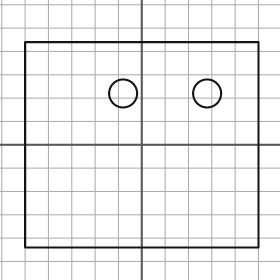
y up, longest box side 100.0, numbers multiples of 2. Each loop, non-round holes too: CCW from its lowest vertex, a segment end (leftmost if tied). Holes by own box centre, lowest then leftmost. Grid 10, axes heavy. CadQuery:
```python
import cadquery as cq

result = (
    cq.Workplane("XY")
    .moveTo(-50.0, -44.0)
    .lineTo(50.0, -44.0)
    .lineTo(50.0, 44.0)
    .lineTo(-50.0, 44.0)
    .close()
    .moveTo(-8.0, 22.0)
    .circle(6.0)
    .moveTo(28.0, 22.0)
    .circle(6.0)
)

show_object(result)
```